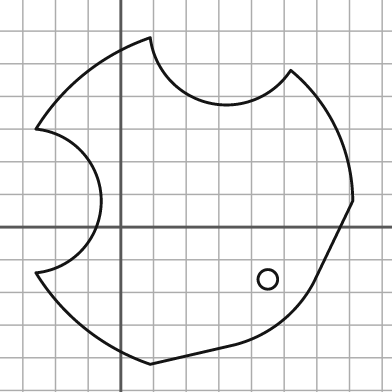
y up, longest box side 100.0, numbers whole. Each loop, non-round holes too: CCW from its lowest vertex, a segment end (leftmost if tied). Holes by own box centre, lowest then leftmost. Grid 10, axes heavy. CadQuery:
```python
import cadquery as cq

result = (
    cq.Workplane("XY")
    .moveTo(9.0, -42.0)
    .lineTo(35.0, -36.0)
    .threePointArc((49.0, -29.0), (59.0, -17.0))
    .lineTo(71.0, 8.0)
    .threePointArc((66.0, 30.0), (52.0, 48.0))
    .threePointArc((27.0, 38.0), (9.0, 58.0))
    .threePointArc((-11.0, 47.0), (-26.0, 30.0))
    .threePointArc((-6.0, 8.0), (-26.0, -14.0))
    .threePointArc((-11.0, -31.0), (9.0, -42.0))
    .close()
    .moveTo(45.0, -16.0)
    .circle(3.0)
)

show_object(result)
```